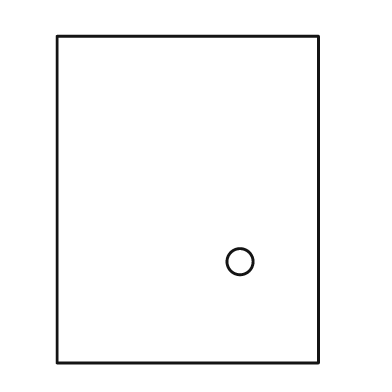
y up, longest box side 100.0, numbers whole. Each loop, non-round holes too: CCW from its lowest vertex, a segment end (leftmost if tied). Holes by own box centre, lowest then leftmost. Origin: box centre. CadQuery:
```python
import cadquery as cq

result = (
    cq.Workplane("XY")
    .moveTo(-40.0, -50.0)
    .lineTo(40.0, -50.0)
    .lineTo(40.0, 50.0)
    .lineTo(-40.0, 50.0)
    .close()
    .moveTo(16.0, -19.0)
    .circle(4.0)
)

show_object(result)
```